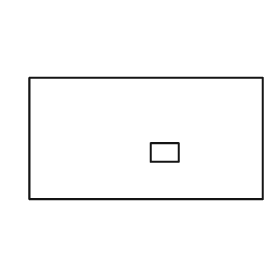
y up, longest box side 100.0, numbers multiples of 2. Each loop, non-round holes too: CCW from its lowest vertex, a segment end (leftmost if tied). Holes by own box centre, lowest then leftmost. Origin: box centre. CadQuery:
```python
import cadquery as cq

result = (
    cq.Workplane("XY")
    .moveTo(-50.0, -26.0)
    .lineTo(50.0, -26.0)
    .lineTo(50.0, 26.0)
    .lineTo(-50.0, 26.0)
    .close()
    .moveTo(2.0, -10.0)
    .lineTo(14.0, -10.0)
    .lineTo(14.0, -2.0)
    .lineTo(2.0, -2.0)
    .close()
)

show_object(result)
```